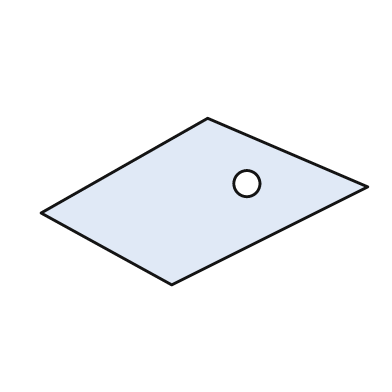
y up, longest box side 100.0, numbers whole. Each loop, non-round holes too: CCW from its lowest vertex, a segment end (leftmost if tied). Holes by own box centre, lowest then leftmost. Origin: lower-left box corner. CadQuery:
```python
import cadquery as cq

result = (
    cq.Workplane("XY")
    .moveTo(40.0, 0.0)
    .lineTo(100.0, 30.0)
    .lineTo(51.0, 51.0)
    .lineTo(0.0, 22.0)
    .close()
    .moveTo(63.0, 31.0)
    .circle(4.0)
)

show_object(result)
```